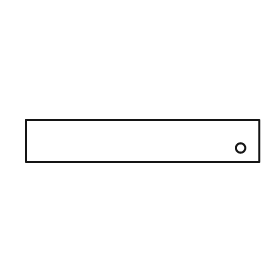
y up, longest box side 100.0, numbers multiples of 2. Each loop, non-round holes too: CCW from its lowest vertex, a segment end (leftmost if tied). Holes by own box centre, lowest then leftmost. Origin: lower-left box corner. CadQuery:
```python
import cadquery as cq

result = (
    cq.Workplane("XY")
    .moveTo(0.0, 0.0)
    .lineTo(100.0, 0.0)
    .lineTo(100.0, 18.0)
    .lineTo(0.0, 18.0)
    .close()
    .moveTo(92.0, 6.0)
    .circle(2.0)
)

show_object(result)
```